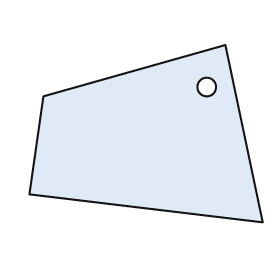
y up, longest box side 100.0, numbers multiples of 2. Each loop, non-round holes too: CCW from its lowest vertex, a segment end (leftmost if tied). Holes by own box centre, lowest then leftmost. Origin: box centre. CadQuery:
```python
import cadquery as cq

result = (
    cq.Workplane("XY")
    .moveTo(50.0, -38.0)
    .lineTo(34.0, 38.0)
    .lineTo(-44.0, 16.0)
    .lineTo(-50.0, -26.0)
    .close()
    .moveTo(26.0, 20.0)
    .circle(4.0)
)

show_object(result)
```